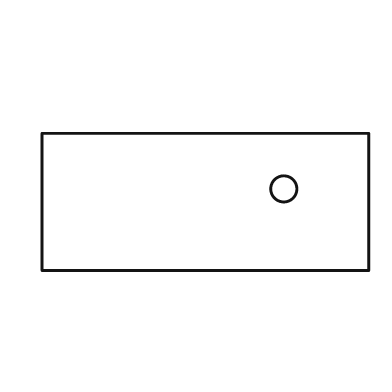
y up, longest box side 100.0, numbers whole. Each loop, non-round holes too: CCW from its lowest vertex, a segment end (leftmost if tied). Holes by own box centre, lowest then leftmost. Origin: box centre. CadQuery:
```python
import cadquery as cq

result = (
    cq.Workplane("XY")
    .moveTo(-50.0, -21.0)
    .lineTo(50.0, -21.0)
    .lineTo(50.0, 21.0)
    .lineTo(-50.0, 21.0)
    .close()
    .moveTo(24.0, 4.0)
    .circle(4.0)
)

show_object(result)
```